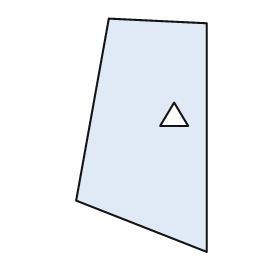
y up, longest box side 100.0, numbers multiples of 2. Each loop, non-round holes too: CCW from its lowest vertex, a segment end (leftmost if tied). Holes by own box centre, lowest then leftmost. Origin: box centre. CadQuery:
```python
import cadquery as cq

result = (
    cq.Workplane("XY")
    .moveTo(28.0, -50.0)
    .lineTo(28.0, 48.0)
    .lineTo(-14.0, 50.0)
    .lineTo(-28.0, -28.0)
    .close()
    .moveTo(8.0, 4.0)
    .lineTo(20.0, 4.0)
    .lineTo(14.0, 14.0)
    .close()
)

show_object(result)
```